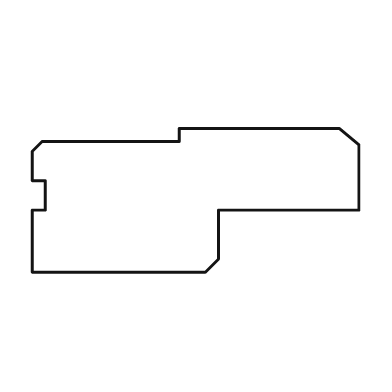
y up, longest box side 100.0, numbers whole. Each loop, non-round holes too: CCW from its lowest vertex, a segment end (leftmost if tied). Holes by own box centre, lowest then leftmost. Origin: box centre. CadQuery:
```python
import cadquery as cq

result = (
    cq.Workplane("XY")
    .moveTo(-50.0, -22.0)
    .lineTo(3.0, -22.0)
    .lineTo(7.0, -18.0)
    .lineTo(7.0, -3.0)
    .lineTo(50.0, -3.0)
    .lineTo(50.0, 17.0)
    .lineTo(44.0, 22.0)
    .lineTo(-5.0, 22.0)
    .lineTo(-5.0, 18.0)
    .lineTo(-47.0, 18.0)
    .lineTo(-50.0, 15.0)
    .lineTo(-50.0, 6.0)
    .lineTo(-46.0, 6.0)
    .lineTo(-46.0, -3.0)
    .lineTo(-50.0, -3.0)
    .close()
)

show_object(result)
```